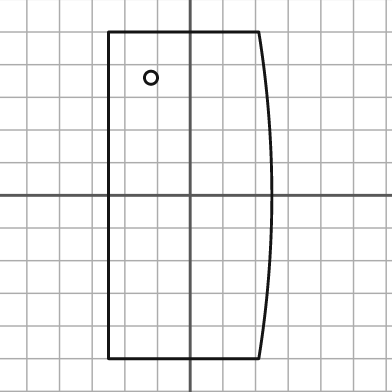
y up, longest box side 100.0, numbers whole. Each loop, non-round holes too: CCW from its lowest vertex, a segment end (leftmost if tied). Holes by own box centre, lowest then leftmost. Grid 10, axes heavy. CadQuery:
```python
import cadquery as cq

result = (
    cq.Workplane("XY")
    .moveTo(-25.0, -50.0)
    .lineTo(21.0, -50.0)
    .threePointArc((25.0, 0.0), (21.0, 50.0))
    .lineTo(-25.0, 50.0)
    .close()
    .moveTo(-12.0, 36.0)
    .circle(2.0)
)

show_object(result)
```